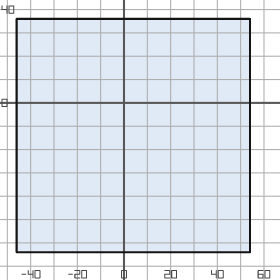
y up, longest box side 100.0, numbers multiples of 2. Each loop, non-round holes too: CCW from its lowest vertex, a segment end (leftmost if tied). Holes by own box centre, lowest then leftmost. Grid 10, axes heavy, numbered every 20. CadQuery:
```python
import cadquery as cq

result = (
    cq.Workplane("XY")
    .moveTo(-46.0, -64.0)
    .lineTo(54.0, -64.0)
    .lineTo(54.0, 36.0)
    .lineTo(-46.0, 36.0)
    .close()
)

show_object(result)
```